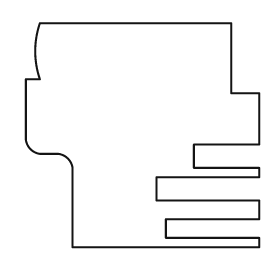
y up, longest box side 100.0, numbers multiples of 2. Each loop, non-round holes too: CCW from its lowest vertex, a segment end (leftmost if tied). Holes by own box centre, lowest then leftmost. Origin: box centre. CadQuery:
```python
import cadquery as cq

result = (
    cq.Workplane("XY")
    .moveTo(-30.0, -48.0)
    .lineTo(50.0, -48.0)
    .lineTo(50.0, -44.0)
    .lineTo(10.0, -44.0)
    .lineTo(10.0, -36.0)
    .lineTo(50.0, -36.0)
    .lineTo(50.0, -28.0)
    .lineTo(6.0, -28.0)
    .lineTo(6.0, -18.0)
    .lineTo(50.0, -18.0)
    .lineTo(50.0, -14.0)
    .lineTo(22.0, -14.0)
    .lineTo(22.0, -4.0)
    .lineTo(50.0, -4.0)
    .lineTo(50.0, 18.0)
    .lineTo(38.0, 18.0)
    .lineTo(38.0, 48.0)
    .lineTo(-44.0, 48.0)
    .threePointArc((-46.0, 36.0), (-44.0, 24.0))
    .lineTo(-50.0, 24.0)
    .lineTo(-50.0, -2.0)
    .threePointArc((-48.0, -6.0), (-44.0, -8.0))
    .lineTo(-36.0, -8.0)
    .threePointArc((-32.0, -10.0), (-30.0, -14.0))
    .close()
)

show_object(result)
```